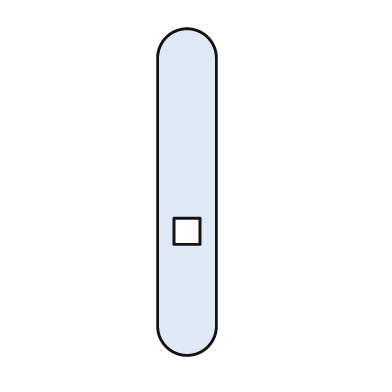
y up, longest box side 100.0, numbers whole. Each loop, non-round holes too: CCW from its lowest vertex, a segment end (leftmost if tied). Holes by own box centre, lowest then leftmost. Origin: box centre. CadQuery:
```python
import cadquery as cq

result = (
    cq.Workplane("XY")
    .moveTo(-9.0, -41.0)
    .threePointArc((0.0, -50.0), (9.0, -41.0))
    .lineTo(9.0, 41.0)
    .threePointArc((0.0, 50.0), (-9.0, 41.0))
    .close()
    .moveTo(-4.0, -16.0)
    .lineTo(4.0, -16.0)
    .lineTo(4.0, -8.0)
    .lineTo(-4.0, -8.0)
    .close()
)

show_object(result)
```